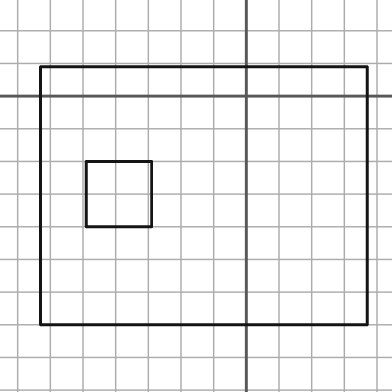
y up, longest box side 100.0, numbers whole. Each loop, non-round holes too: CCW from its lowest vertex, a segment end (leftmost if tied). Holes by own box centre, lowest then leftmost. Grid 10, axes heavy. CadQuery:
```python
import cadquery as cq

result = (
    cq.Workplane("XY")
    .moveTo(-63.0, -70.0)
    .lineTo(37.0, -70.0)
    .lineTo(37.0, 9.0)
    .lineTo(-63.0, 9.0)
    .close()
    .moveTo(-49.0, -40.0)
    .lineTo(-29.0, -40.0)
    .lineTo(-29.0, -20.0)
    .lineTo(-49.0, -20.0)
    .close()
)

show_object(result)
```